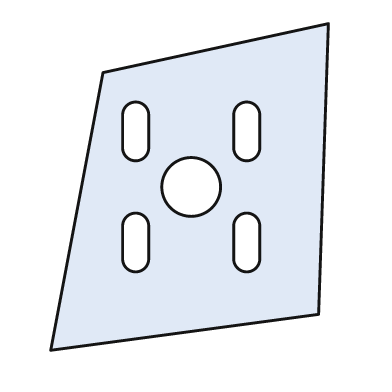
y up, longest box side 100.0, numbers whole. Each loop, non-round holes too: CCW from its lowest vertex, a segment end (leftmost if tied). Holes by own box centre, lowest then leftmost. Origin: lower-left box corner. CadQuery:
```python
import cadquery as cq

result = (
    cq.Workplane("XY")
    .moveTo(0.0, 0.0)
    .lineTo(82.0, 11.0)
    .lineTo(85.0, 100.0)
    .lineTo(16.0, 85.0)
    .close()
    .moveTo(22.0, 28.0)
    .threePointArc((26.0, 24.0), (30.0, 28.0))
    .lineTo(30.0, 38.0)
    .threePointArc((26.0, 42.0), (22.0, 38.0))
    .close()
    .moveTo(56.0, 28.0)
    .threePointArc((60.0, 24.0), (64.0, 28.0))
    .lineTo(64.0, 38.0)
    .threePointArc((60.0, 42.0), (56.0, 38.0))
    .close()
    .moveTo(43.0, 50.0)
    .circle(9.0)
    .moveTo(22.0, 62.0)
    .threePointArc((26.0, 58.0), (30.0, 62.0))
    .lineTo(30.0, 72.0)
    .threePointArc((26.0, 76.0), (22.0, 72.0))
    .close()
    .moveTo(56.0, 62.0)
    .threePointArc((60.0, 58.0), (64.0, 62.0))
    .lineTo(64.0, 72.0)
    .threePointArc((60.0, 76.0), (56.0, 72.0))
    .close()
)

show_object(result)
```